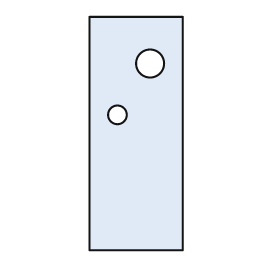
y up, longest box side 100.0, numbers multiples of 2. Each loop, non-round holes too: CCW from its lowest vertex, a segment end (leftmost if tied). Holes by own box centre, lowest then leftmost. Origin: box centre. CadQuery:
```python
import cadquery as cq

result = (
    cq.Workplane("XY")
    .moveTo(-20.0, -50.0)
    .lineTo(20.0, -50.0)
    .lineTo(20.0, 50.0)
    .lineTo(-20.0, 50.0)
    .close()
    .moveTo(-8.0, 8.0)
    .circle(4.0)
    .moveTo(6.0, 30.0)
    .circle(6.0)
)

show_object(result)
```